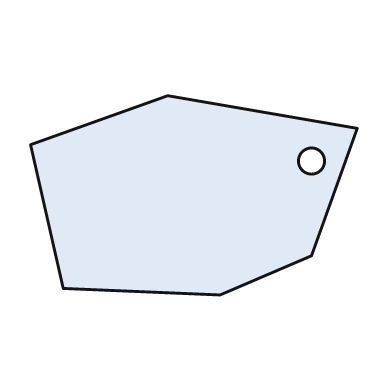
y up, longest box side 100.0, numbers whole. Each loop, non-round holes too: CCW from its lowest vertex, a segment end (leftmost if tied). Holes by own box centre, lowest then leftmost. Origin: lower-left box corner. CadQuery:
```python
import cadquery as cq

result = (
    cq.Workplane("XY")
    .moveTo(58.0, 0.0)
    .lineTo(86.0, 12.0)
    .lineTo(100.0, 51.0)
    .lineTo(42.0, 61.0)
    .lineTo(0.0, 46.0)
    .lineTo(10.0, 2.0)
    .close()
    .moveTo(86.0, 41.0)
    .circle(4.0)
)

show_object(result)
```